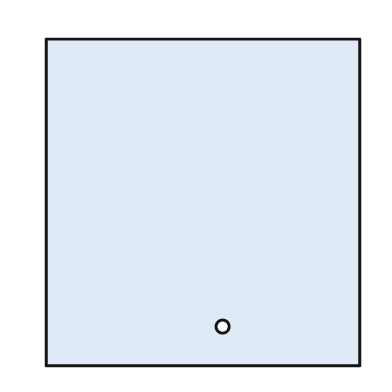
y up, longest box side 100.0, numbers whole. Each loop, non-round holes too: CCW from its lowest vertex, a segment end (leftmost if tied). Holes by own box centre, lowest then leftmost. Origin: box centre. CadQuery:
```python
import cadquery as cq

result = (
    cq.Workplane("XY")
    .moveTo(-48.0, -50.0)
    .lineTo(48.0, -50.0)
    .lineTo(48.0, 50.0)
    .lineTo(-48.0, 50.0)
    .close()
    .moveTo(6.0, -38.0)
    .circle(2.0)
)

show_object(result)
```